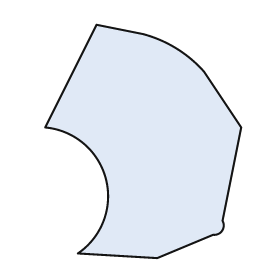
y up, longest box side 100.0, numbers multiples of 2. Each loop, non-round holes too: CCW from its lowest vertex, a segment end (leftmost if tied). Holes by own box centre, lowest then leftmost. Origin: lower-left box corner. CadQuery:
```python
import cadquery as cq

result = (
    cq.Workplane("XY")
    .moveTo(48.0, 0.0)
    .lineTo(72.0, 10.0)
    .threePointArc((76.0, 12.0), (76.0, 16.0))
    .lineTo(84.0, 56.0)
    .lineTo(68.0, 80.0)
    .threePointArc((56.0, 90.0), (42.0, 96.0))
    .lineTo(22.0, 100.0)
    .lineTo(0.0, 56.0)
    .threePointArc((26.0, 34.0), (14.0, 2.0))
    .close()
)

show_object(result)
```